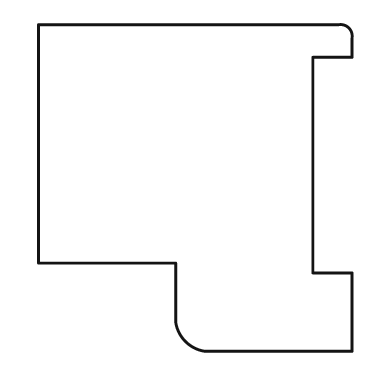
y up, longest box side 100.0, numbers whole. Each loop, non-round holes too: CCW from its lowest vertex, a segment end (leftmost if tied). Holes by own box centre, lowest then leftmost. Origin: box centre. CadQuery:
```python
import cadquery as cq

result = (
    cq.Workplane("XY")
    .moveTo(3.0, -50.0)
    .lineTo(48.0, -50.0)
    .lineTo(48.0, -26.0)
    .lineTo(36.0, -26.0)
    .lineTo(36.0, 40.0)
    .lineTo(48.0, 40.0)
    .lineTo(48.0, 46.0)
    .threePointArc((47.0, 49.0), (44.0, 50.0))
    .lineTo(-48.0, 50.0)
    .lineTo(-48.0, -23.0)
    .lineTo(-6.0, -23.0)
    .lineTo(-6.0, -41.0)
    .threePointArc((-3.0, -47.0), (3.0, -50.0))
    .close()
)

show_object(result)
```